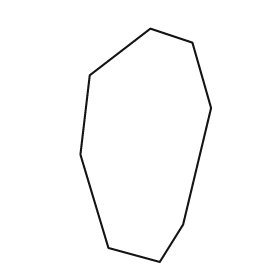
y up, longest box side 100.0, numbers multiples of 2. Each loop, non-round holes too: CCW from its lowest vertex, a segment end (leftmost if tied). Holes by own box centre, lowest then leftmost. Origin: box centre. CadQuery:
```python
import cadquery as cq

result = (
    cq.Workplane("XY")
    .moveTo(6.0, -50.0)
    .lineTo(16.0, -34.0)
    .lineTo(28.0, 16.0)
    .lineTo(20.0, 44.0)
    .lineTo(2.0, 50.0)
    .lineTo(-24.0, 30.0)
    .lineTo(-28.0, -4.0)
    .lineTo(-16.0, -44.0)
    .close()
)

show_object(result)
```